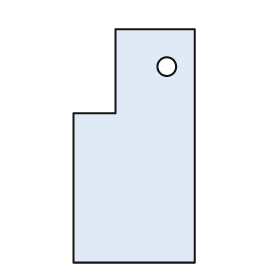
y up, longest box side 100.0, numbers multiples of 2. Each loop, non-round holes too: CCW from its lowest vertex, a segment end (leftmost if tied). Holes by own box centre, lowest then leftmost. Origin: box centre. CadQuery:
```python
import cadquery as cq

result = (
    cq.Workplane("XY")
    .moveTo(-26.0, -50.0)
    .lineTo(26.0, -50.0)
    .lineTo(26.0, 50.0)
    .lineTo(-8.0, 50.0)
    .lineTo(-8.0, 14.0)
    .lineTo(-26.0, 14.0)
    .close()
    .moveTo(14.0, 34.0)
    .circle(4.0)
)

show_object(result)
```